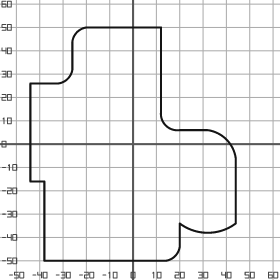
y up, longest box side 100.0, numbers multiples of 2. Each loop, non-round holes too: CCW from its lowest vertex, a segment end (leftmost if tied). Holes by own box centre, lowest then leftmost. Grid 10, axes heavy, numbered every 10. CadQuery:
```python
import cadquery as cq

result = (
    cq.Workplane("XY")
    .moveTo(-38.0, -50.0)
    .lineTo(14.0, -50.0)
    .threePointArc((18.0, -48.0), (20.0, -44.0))
    .lineTo(20.0, -34.0)
    .threePointArc((32.0, -38.0), (44.0, -34.0))
    .lineTo(44.0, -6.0)
    .threePointArc((40.0, 2.0), (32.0, 6.0))
    .lineTo(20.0, 6.0)
    .threePointArc((14.0, 8.0), (12.0, 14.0))
    .lineTo(12.0, 50.0)
    .lineTo(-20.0, 50.0)
    .threePointArc((-24.0, 48.0), (-26.0, 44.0))
    .lineTo(-26.0, 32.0)
    .threePointArc((-28.0, 28.0), (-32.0, 26.0))
    .lineTo(-44.0, 26.0)
    .lineTo(-44.0, -16.0)
    .lineTo(-38.0, -16.0)
    .close()
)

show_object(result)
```